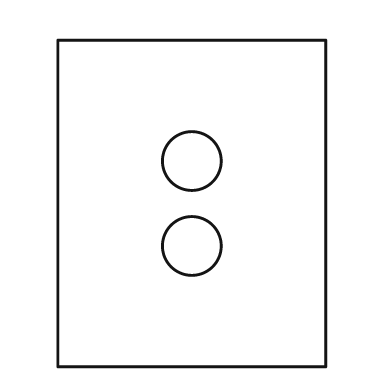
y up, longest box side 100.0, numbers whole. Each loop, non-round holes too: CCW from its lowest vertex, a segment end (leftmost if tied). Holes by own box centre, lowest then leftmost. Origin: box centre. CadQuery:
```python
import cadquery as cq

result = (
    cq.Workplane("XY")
    .moveTo(-41.0, -50.0)
    .lineTo(41.0, -50.0)
    .lineTo(41.0, 50.0)
    .lineTo(-41.0, 50.0)
    .close()
    .moveTo(0.0, -13.0)
    .circle(9.0)
    .moveTo(0.0, 13.0)
    .circle(9.0)
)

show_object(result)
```